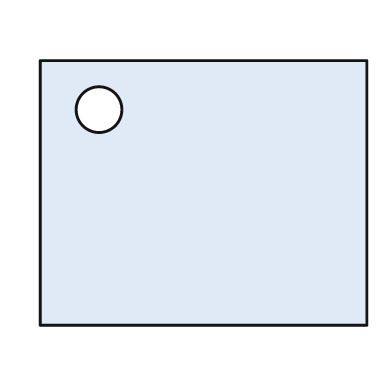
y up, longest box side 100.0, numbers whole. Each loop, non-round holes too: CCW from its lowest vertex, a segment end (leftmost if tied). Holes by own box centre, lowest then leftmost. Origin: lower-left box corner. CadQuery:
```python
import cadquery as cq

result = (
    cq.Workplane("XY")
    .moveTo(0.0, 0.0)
    .lineTo(100.0, 0.0)
    .lineTo(100.0, 81.0)
    .lineTo(0.0, 81.0)
    .close()
    .moveTo(18.0, 66.0)
    .circle(7.0)
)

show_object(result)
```